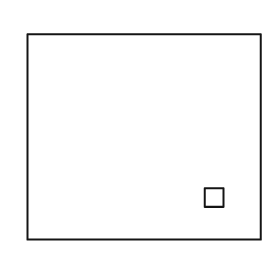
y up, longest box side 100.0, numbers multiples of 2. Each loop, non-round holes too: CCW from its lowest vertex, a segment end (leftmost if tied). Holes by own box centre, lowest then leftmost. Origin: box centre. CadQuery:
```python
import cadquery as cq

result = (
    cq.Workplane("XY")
    .moveTo(-50.0, -44.0)
    .lineTo(50.0, -44.0)
    .lineTo(50.0, 44.0)
    .lineTo(-50.0, 44.0)
    .close()
    .moveTo(26.0, -30.0)
    .lineTo(34.0, -30.0)
    .lineTo(34.0, -22.0)
    .lineTo(26.0, -22.0)
    .close()
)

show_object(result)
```